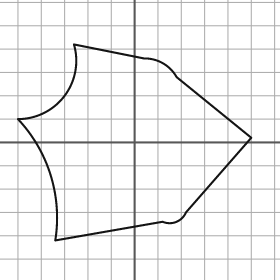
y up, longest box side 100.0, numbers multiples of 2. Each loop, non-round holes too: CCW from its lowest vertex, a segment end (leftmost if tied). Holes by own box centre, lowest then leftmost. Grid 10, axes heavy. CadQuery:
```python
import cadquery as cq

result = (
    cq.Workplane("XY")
    .moveTo(-34.0, -42.0)
    .lineTo(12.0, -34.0)
    .threePointArc((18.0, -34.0), (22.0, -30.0))
    .lineTo(50.0, 2.0)
    .lineTo(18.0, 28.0)
    .threePointArc((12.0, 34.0), (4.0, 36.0))
    .lineTo(-26.0, 42.0)
    .threePointArc((-30.0, 20.0), (-50.0, 10.0))
    .threePointArc((-36.0, -14.0), (-34.0, -42.0))
    .close()
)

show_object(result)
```